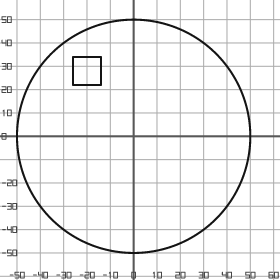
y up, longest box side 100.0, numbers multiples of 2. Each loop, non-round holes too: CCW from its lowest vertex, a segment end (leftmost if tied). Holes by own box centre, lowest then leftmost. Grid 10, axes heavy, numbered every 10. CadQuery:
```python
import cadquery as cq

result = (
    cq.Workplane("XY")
    .moveTo(0.0, 0.0)
    .circle(50.0)
    .moveTo(-26.0, 22.0)
    .lineTo(-14.0, 22.0)
    .lineTo(-14.0, 34.0)
    .lineTo(-26.0, 34.0)
    .close()
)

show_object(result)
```